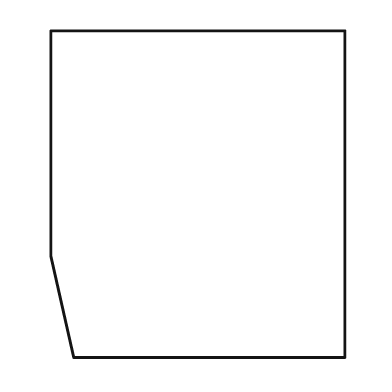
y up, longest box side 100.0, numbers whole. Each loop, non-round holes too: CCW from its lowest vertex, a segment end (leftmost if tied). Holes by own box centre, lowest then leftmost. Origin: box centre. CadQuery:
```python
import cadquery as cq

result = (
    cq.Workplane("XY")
    .moveTo(-38.0, -50.0)
    .lineTo(45.0, -50.0)
    .lineTo(45.0, 50.0)
    .lineTo(-45.0, 50.0)
    .lineTo(-45.0, -19.0)
    .close()
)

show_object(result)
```